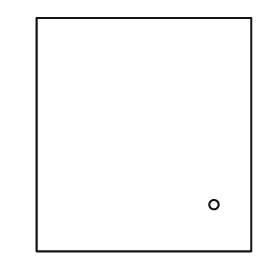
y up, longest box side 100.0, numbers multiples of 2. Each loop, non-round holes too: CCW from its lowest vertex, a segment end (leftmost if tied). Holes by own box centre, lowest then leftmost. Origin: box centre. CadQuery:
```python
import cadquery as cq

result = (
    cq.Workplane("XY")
    .moveTo(-46.0, -50.0)
    .lineTo(46.0, -50.0)
    .lineTo(46.0, 50.0)
    .lineTo(-46.0, 50.0)
    .close()
    .moveTo(30.0, -30.0)
    .circle(2.0)
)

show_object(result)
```